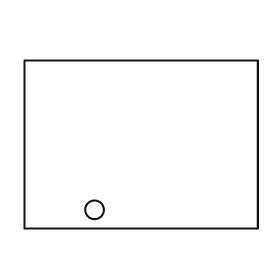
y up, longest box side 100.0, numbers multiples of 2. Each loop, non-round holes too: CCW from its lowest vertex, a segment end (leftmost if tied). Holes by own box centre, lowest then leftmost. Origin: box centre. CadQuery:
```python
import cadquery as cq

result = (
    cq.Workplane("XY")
    .moveTo(-50.0, -36.0)
    .lineTo(50.0, -36.0)
    .lineTo(50.0, 36.0)
    .lineTo(-50.0, 36.0)
    .close()
    .moveTo(-20.0, -28.0)
    .circle(4.0)
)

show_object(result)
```